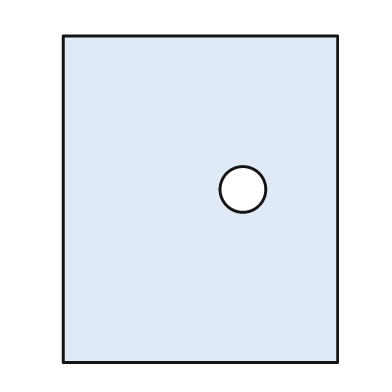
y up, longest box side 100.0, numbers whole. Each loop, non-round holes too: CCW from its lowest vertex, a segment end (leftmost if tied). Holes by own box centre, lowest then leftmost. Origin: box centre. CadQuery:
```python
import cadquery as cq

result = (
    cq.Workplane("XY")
    .moveTo(-42.0, -50.0)
    .lineTo(42.0, -50.0)
    .lineTo(42.0, 50.0)
    .lineTo(-42.0, 50.0)
    .close()
    .moveTo(13.0, 3.0)
    .circle(7.0)
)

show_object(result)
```